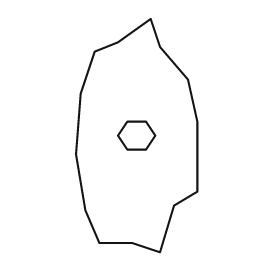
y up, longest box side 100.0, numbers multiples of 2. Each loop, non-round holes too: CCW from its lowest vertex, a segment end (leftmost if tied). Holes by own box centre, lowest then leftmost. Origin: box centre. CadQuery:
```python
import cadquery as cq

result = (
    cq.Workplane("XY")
    .moveTo(10.0, -50.0)
    .lineTo(16.0, -30.0)
    .lineTo(26.0, -24.0)
    .lineTo(26.0, 6.0)
    .lineTo(22.0, 24.0)
    .lineTo(10.0, 38.0)
    .lineTo(6.0, 50.0)
    .lineTo(-8.0, 40.0)
    .lineTo(-18.0, 36.0)
    .lineTo(-24.0, 18.0)
    .lineTo(-26.0, -8.0)
    .lineTo(-22.0, -32.0)
    .lineTo(-16.0, -46.0)
    .lineTo(-2.0, -46.0)
    .close()
    .moveTo(-4.0, -6.0)
    .lineTo(4.0, -6.0)
    .lineTo(8.0, 0.0)
    .lineTo(4.0, 6.0)
    .lineTo(-4.0, 6.0)
    .lineTo(-8.0, 0.0)
    .close()
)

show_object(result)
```